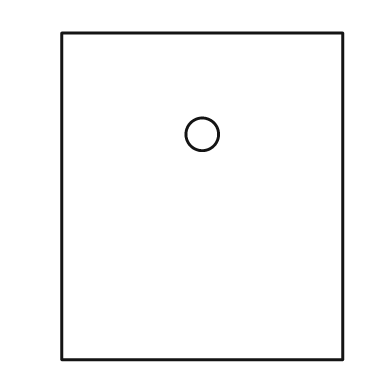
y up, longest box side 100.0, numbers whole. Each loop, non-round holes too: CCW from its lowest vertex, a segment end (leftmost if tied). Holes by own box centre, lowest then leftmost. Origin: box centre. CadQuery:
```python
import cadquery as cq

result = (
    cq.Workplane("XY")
    .moveTo(-43.0, -50.0)
    .lineTo(43.0, -50.0)
    .lineTo(43.0, 50.0)
    .lineTo(-43.0, 50.0)
    .close()
    .moveTo(0.0, 19.0)
    .circle(5.0)
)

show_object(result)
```